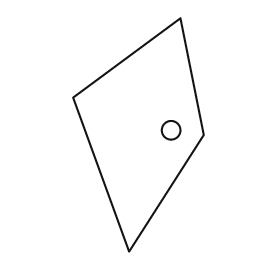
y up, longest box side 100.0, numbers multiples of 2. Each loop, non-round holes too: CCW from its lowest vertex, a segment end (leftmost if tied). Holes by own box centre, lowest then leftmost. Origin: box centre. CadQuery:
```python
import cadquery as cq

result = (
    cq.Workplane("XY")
    .moveTo(-4.0, -50.0)
    .lineTo(28.0, 0.0)
    .lineTo(18.0, 50.0)
    .lineTo(-28.0, 16.0)
    .close()
    .moveTo(14.0, 2.0)
    .circle(4.0)
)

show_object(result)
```